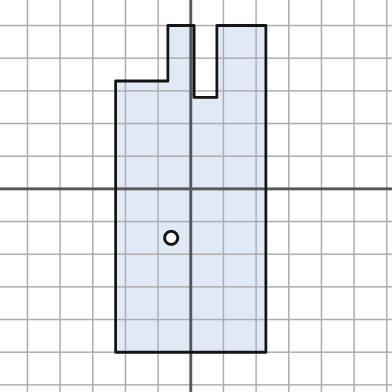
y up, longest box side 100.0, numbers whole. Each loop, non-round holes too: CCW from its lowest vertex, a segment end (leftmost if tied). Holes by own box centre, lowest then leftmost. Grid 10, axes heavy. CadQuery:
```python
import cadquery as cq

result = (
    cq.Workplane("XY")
    .moveTo(-23.0, -50.0)
    .lineTo(23.0, -50.0)
    .lineTo(23.0, 50.0)
    .lineTo(8.0, 50.0)
    .lineTo(8.0, 28.0)
    .lineTo(1.0, 28.0)
    .lineTo(1.0, 50.0)
    .lineTo(-7.0, 50.0)
    .lineTo(-7.0, 33.0)
    .lineTo(-23.0, 33.0)
    .close()
    .moveTo(-6.0, -15.0)
    .circle(2.0)
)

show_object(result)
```